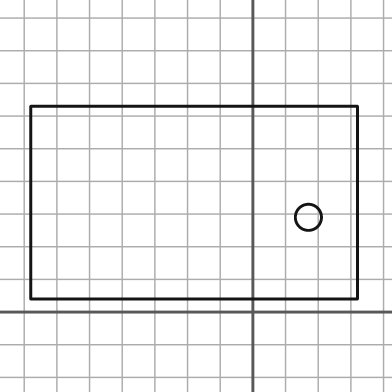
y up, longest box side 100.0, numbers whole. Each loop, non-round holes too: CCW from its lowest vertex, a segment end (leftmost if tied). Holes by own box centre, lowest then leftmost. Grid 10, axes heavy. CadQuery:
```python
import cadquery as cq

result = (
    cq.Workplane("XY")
    .moveTo(-68.0, 4.0)
    .lineTo(32.0, 4.0)
    .lineTo(32.0, 63.0)
    .lineTo(-68.0, 63.0)
    .close()
    .moveTo(17.0, 29.0)
    .circle(4.0)
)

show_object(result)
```